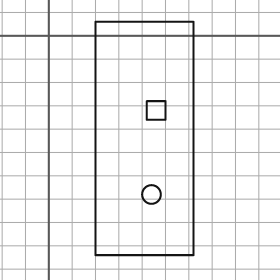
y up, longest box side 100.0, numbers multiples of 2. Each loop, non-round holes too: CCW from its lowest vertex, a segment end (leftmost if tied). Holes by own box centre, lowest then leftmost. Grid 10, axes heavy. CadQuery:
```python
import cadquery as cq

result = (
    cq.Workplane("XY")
    .moveTo(20.0, -94.0)
    .lineTo(62.0, -94.0)
    .lineTo(62.0, 6.0)
    .lineTo(20.0, 6.0)
    .close()
    .moveTo(44.0, -68.0)
    .circle(4.0)
    .moveTo(42.0, -36.0)
    .lineTo(50.0, -36.0)
    .lineTo(50.0, -28.0)
    .lineTo(42.0, -28.0)
    .close()
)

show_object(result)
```